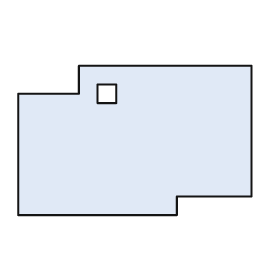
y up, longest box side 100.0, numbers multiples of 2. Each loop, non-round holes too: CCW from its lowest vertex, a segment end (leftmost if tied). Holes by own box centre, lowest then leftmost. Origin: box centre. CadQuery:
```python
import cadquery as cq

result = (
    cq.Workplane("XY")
    .moveTo(-50.0, -32.0)
    .lineTo(18.0, -32.0)
    .lineTo(18.0, -24.0)
    .lineTo(50.0, -24.0)
    .lineTo(50.0, 32.0)
    .lineTo(-24.0, 32.0)
    .lineTo(-24.0, 20.0)
    .lineTo(-50.0, 20.0)
    .close()
    .moveTo(-16.0, 16.0)
    .lineTo(-8.0, 16.0)
    .lineTo(-8.0, 24.0)
    .lineTo(-16.0, 24.0)
    .close()
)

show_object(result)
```